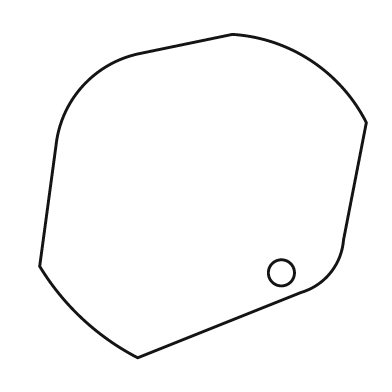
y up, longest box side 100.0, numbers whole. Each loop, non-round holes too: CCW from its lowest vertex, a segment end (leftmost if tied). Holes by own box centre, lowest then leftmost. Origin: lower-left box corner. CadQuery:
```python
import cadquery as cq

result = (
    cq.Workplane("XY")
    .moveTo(30.0, 0.0)
    .lineTo(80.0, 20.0)
    .threePointArc((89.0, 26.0), (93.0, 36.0))
    .lineTo(100.0, 72.0)
    .threePointArc((83.0, 91.0), (59.0, 99.0))
    .lineTo(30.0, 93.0)
    .threePointArc((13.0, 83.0), (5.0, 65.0))
    .lineTo(0.0, 28.0)
    .threePointArc((13.0, 12.0), (30.0, 0.0))
    .close()
    .moveTo(74.0, 26.0)
    .circle(4.0)
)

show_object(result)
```